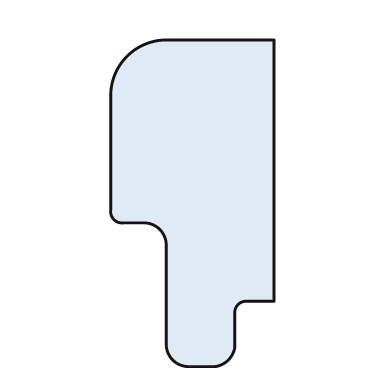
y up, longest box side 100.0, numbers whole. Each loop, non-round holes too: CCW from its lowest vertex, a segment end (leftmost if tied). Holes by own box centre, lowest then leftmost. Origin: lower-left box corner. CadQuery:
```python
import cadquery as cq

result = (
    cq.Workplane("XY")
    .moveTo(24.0, 0.0)
    .lineTo(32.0, 0.0)
    .threePointArc((36.0, 2.0), (38.0, 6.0))
    .lineTo(38.0, 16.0)
    .threePointArc((39.0, 19.0), (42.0, 20.0))
    .lineTo(50.0, 20.0)
    .lineTo(50.0, 100.0)
    .lineTo(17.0, 100.0)
    .threePointArc((5.0, 95.0), (0.0, 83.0))
    .lineTo(0.0, 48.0)
    .threePointArc((1.0, 45.0), (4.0, 44.0))
    .lineTo(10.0, 44.0)
    .threePointArc((15.0, 42.0), (17.0, 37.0))
    .lineTo(17.0, 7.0)
    .threePointArc((19.0, 2.0), (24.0, 0.0))
    .close()
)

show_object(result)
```